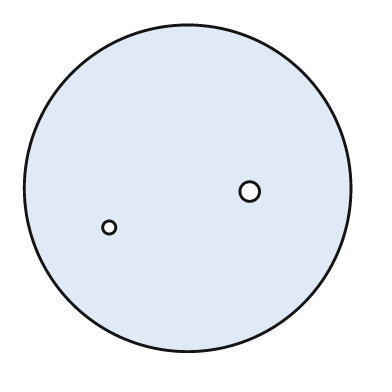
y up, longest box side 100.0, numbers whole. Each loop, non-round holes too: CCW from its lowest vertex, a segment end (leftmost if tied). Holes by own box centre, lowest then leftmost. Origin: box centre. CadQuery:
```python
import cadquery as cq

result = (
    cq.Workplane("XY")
    .moveTo(0.0, 0.0)
    .circle(50.0)
    .moveTo(-24.0, -12.0)
    .circle(2.0)
    .moveTo(19.0, -1.0)
    .circle(3.0)
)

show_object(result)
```